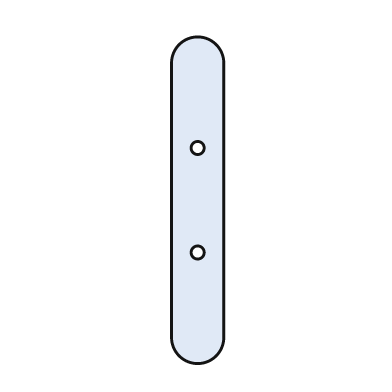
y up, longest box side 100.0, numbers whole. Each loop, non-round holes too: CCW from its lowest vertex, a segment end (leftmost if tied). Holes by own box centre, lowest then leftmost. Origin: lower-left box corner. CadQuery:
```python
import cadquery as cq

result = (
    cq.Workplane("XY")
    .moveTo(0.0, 8.0)
    .threePointArc((8.0, 0.0), (16.0, 8.0))
    .lineTo(16.0, 92.0)
    .threePointArc((8.0, 100.0), (0.0, 92.0))
    .close()
    .moveTo(8.0, 34.0)
    .circle(2.0)
    .moveTo(8.0, 66.0)
    .circle(2.0)
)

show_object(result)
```